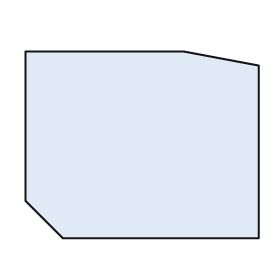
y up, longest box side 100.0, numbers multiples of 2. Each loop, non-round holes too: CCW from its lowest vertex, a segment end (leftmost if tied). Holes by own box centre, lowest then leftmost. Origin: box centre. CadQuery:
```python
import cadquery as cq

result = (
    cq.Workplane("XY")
    .moveTo(-34.0, -40.0)
    .lineTo(50.0, -40.0)
    .lineTo(50.0, 34.0)
    .lineTo(18.0, 40.0)
    .lineTo(-50.0, 40.0)
    .lineTo(-50.0, -24.0)
    .close()
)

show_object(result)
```